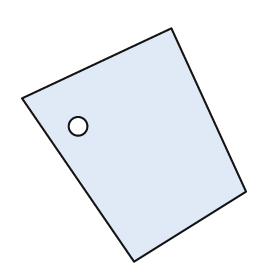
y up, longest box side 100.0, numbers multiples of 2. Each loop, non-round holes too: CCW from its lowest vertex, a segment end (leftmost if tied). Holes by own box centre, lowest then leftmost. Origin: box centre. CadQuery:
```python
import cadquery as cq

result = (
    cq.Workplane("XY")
    .moveTo(0.0, -50.0)
    .lineTo(48.0, -20.0)
    .lineTo(16.0, 50.0)
    .lineTo(-48.0, 20.0)
    .close()
    .moveTo(-24.0, 8.0)
    .circle(4.0)
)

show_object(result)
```